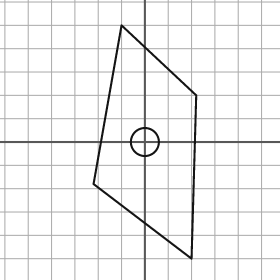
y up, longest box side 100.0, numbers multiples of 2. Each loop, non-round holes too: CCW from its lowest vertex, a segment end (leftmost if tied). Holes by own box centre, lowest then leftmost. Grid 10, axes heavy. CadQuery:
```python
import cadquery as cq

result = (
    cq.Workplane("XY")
    .moveTo(20.0, -50.0)
    .lineTo(22.0, 20.0)
    .lineTo(-10.0, 50.0)
    .lineTo(-22.0, -18.0)
    .close()
    .moveTo(0.0, 0.0)
    .circle(6.0)
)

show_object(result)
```